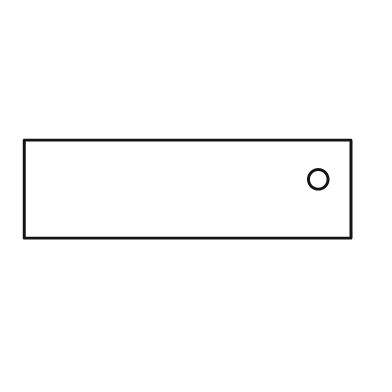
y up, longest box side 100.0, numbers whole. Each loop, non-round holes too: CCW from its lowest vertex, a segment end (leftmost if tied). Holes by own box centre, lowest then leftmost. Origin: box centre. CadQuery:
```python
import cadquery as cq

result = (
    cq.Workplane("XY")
    .moveTo(-50.0, -15.0)
    .lineTo(50.0, -15.0)
    .lineTo(50.0, 15.0)
    .lineTo(-50.0, 15.0)
    .close()
    .moveTo(40.0, 3.0)
    .circle(3.0)
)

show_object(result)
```